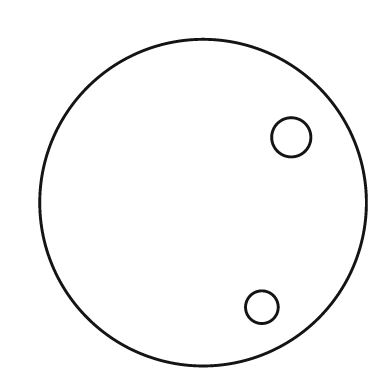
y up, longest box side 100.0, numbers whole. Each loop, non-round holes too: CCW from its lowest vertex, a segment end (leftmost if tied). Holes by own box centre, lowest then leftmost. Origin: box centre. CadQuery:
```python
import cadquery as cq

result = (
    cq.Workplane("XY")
    .moveTo(0.0, 0.0)
    .circle(50.0)
    .moveTo(18.0, -32.0)
    .circle(5.0)
    .moveTo(27.0, 20.0)
    .circle(6.0)
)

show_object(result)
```